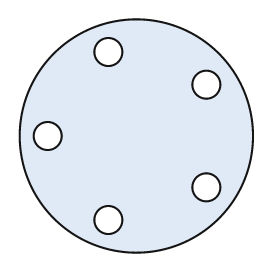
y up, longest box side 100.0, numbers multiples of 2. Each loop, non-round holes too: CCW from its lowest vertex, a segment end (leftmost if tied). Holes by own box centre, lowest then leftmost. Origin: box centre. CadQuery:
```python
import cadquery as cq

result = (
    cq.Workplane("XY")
    .moveTo(0.0, 0.0)
    .circle(50.0)
    .moveTo(-12.0, -36.0)
    .circle(6.0)
    .moveTo(30.0, -22.0)
    .circle(6.0)
    .moveTo(-38.0, 0.0)
    .circle(6.0)
    .moveTo(30.0, 22.0)
    .circle(6.0)
    .moveTo(-12.0, 36.0)
    .circle(6.0)
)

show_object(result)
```